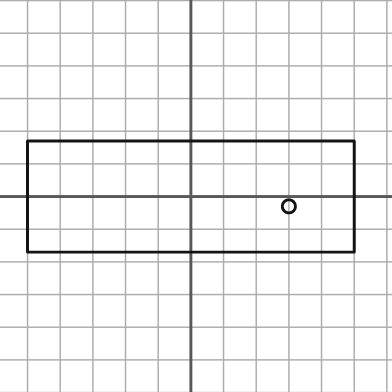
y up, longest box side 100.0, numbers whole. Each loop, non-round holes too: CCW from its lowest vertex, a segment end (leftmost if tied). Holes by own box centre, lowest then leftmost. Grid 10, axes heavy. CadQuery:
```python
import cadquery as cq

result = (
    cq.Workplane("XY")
    .moveTo(-50.0, -17.0)
    .lineTo(50.0, -17.0)
    .lineTo(50.0, 17.0)
    .lineTo(-50.0, 17.0)
    .close()
    .moveTo(30.0, -3.0)
    .circle(2.0)
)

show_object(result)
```